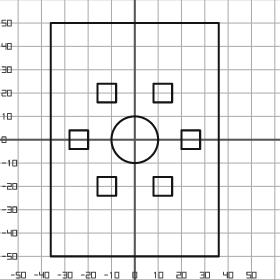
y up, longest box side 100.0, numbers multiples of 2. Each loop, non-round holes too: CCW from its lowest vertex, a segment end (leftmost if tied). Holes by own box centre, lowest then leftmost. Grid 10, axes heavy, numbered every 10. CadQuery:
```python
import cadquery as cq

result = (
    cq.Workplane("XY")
    .moveTo(-36.0, -50.0)
    .lineTo(36.0, -50.0)
    .lineTo(36.0, 50.0)
    .lineTo(-36.0, 50.0)
    .close()
    .moveTo(-16.0, -24.0)
    .lineTo(-8.0, -24.0)
    .lineTo(-8.0, -16.0)
    .lineTo(-16.0, -16.0)
    .close()
    .moveTo(8.0, -24.0)
    .lineTo(16.0, -24.0)
    .lineTo(16.0, -16.0)
    .lineTo(8.0, -16.0)
    .close()
    .moveTo(-28.0, -4.0)
    .lineTo(-20.0, -4.0)
    .lineTo(-20.0, 4.0)
    .lineTo(-28.0, 4.0)
    .close()
    .moveTo(0.0, 0.0)
    .circle(10.0)
    .moveTo(20.0, -4.0)
    .lineTo(28.0, -4.0)
    .lineTo(28.0, 4.0)
    .lineTo(20.0, 4.0)
    .close()
    .moveTo(-16.0, 16.0)
    .lineTo(-8.0, 16.0)
    .lineTo(-8.0, 24.0)
    .lineTo(-16.0, 24.0)
    .close()
    .moveTo(8.0, 16.0)
    .lineTo(16.0, 16.0)
    .lineTo(16.0, 24.0)
    .lineTo(8.0, 24.0)
    .close()
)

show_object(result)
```